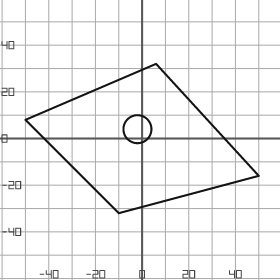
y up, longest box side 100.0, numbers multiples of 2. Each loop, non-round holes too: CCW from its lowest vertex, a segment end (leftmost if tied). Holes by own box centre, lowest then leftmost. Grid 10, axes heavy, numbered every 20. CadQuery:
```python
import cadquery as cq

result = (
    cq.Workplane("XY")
    .moveTo(-10.0, -32.0)
    .lineTo(50.0, -16.0)
    .lineTo(6.0, 32.0)
    .lineTo(-50.0, 8.0)
    .close()
    .moveTo(-2.0, 4.0)
    .circle(6.0)
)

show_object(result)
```